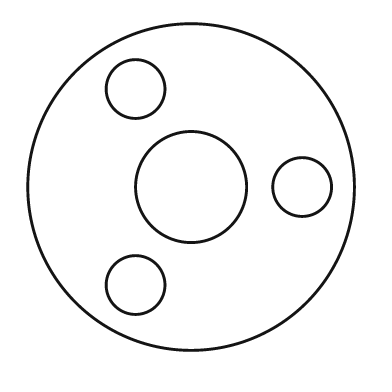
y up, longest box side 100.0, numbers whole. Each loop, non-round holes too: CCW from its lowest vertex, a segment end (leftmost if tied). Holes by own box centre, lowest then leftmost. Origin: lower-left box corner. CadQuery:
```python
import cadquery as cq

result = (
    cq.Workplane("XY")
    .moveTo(50.0, 50.0)
    .circle(50.0)
    .moveTo(33.0, 20.0)
    .circle(9.0)
    .moveTo(50.0, 50.0)
    .circle(17.0)
    .moveTo(84.0, 50.0)
    .circle(9.0)
    .moveTo(33.0, 80.0)
    .circle(9.0)
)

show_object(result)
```